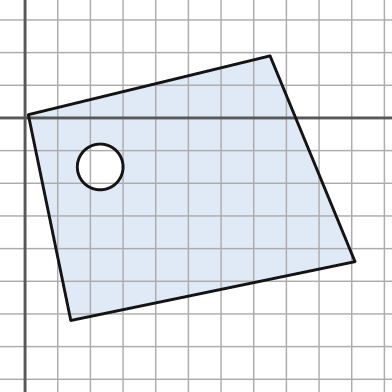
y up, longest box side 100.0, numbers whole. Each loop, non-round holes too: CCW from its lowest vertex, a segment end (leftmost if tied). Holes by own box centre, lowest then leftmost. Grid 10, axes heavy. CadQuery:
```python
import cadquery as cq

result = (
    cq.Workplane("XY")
    .moveTo(14.0, -62.0)
    .lineTo(101.0, -44.0)
    .lineTo(75.0, 19.0)
    .lineTo(1.0, 1.0)
    .close()
    .moveTo(23.0, -15.0)
    .circle(7.0)
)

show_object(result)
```